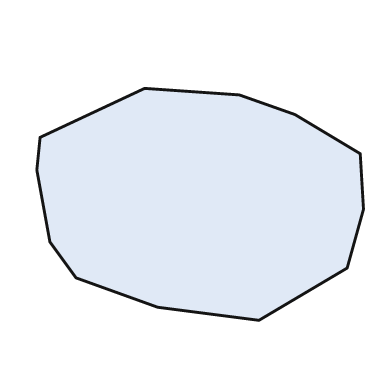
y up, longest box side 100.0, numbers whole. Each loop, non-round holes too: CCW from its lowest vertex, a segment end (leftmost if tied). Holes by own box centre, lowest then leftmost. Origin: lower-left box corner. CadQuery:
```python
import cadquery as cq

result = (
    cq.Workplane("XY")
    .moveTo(68.0, 0.0)
    .lineTo(95.0, 16.0)
    .lineTo(100.0, 34.0)
    .lineTo(99.0, 51.0)
    .lineTo(79.0, 63.0)
    .lineTo(62.0, 69.0)
    .lineTo(33.0, 71.0)
    .lineTo(1.0, 56.0)
    .lineTo(0.0, 46.0)
    .lineTo(4.0, 24.0)
    .lineTo(12.0, 13.0)
    .lineTo(37.0, 4.0)
    .close()
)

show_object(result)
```